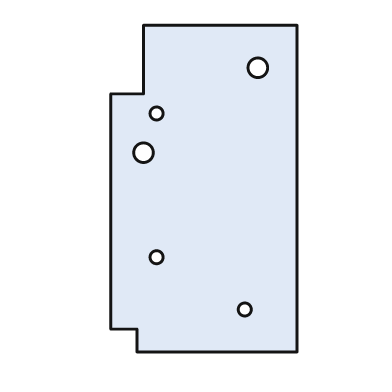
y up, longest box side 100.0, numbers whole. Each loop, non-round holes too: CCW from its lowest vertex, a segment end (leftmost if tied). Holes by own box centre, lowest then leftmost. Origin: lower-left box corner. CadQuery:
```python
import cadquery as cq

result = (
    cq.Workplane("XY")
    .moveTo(8.0, 0.0)
    .lineTo(57.0, 0.0)
    .lineTo(57.0, 100.0)
    .lineTo(10.0, 100.0)
    .lineTo(10.0, 79.0)
    .lineTo(0.0, 79.0)
    .lineTo(0.0, 7.0)
    .lineTo(8.0, 7.0)
    .close()
    .moveTo(41.0, 13.0)
    .circle(2.0)
    .moveTo(14.0, 29.0)
    .circle(2.0)
    .moveTo(10.0, 61.0)
    .circle(3.0)
    .moveTo(14.0, 73.0)
    .circle(2.0)
    .moveTo(45.0, 87.0)
    .circle(3.0)
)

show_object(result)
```